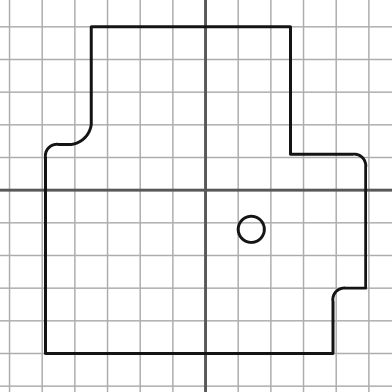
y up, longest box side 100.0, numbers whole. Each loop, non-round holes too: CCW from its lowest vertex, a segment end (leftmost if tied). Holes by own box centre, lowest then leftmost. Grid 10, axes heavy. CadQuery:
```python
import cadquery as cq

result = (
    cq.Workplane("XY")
    .moveTo(-49.0, -50.0)
    .lineTo(39.0, -50.0)
    .lineTo(39.0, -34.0)
    .threePointArc((40.0, -31.0), (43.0, -30.0))
    .lineTo(49.0, -30.0)
    .lineTo(49.0, 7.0)
    .threePointArc((48.0, 10.0), (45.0, 11.0))
    .lineTo(26.0, 11.0)
    .lineTo(26.0, 50.0)
    .lineTo(-35.0, 50.0)
    .lineTo(-35.0, 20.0)
    .threePointArc((-37.0, 16.0), (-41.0, 14.0))
    .lineTo(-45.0, 14.0)
    .threePointArc((-48.0, 13.0), (-49.0, 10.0))
    .close()
    .moveTo(14.0, -12.0)
    .circle(4.0)
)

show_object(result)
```